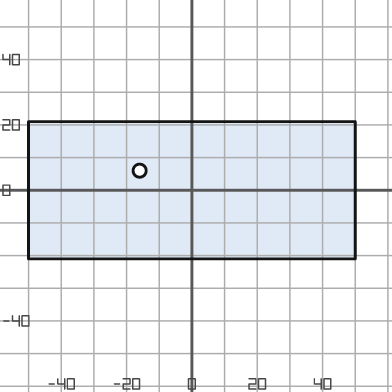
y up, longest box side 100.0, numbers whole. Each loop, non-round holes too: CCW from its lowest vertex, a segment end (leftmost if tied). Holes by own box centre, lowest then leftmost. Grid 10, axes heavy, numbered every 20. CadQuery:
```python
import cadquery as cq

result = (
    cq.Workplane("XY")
    .moveTo(-50.0, -21.0)
    .lineTo(50.0, -21.0)
    .lineTo(50.0, 21.0)
    .lineTo(-50.0, 21.0)
    .close()
    .moveTo(-16.0, 6.0)
    .circle(2.0)
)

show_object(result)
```